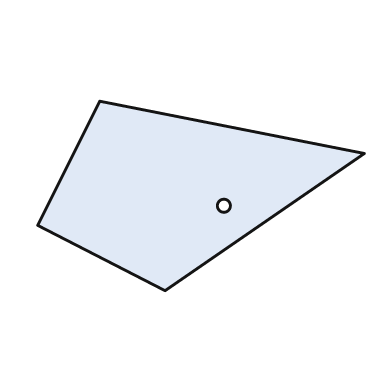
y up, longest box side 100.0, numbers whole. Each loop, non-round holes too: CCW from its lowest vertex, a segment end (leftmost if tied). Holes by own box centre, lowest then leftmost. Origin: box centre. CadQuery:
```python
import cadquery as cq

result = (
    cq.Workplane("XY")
    .moveTo(-11.0, -29.0)
    .lineTo(50.0, 13.0)
    .lineTo(-31.0, 29.0)
    .lineTo(-50.0, -9.0)
    .close()
    .moveTo(7.0, -3.0)
    .circle(2.0)
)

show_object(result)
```